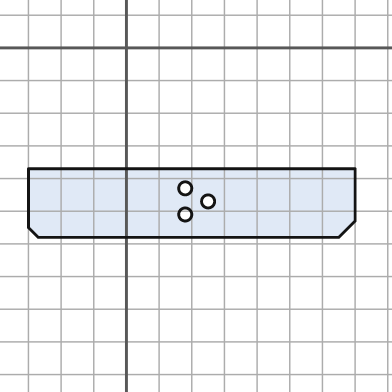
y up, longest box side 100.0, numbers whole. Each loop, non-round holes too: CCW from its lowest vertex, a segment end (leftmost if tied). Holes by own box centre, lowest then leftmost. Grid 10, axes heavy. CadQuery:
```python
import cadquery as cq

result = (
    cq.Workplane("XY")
    .moveTo(-27.0, -58.0)
    .lineTo(65.0, -58.0)
    .lineTo(70.0, -53.0)
    .lineTo(70.0, -37.0)
    .lineTo(-30.0, -37.0)
    .lineTo(-30.0, -55.0)
    .close()
    .moveTo(18.0, -51.0)
    .circle(2.0)
    .moveTo(25.0, -47.0)
    .circle(2.0)
    .moveTo(18.0, -43.0)
    .circle(2.0)
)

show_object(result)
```